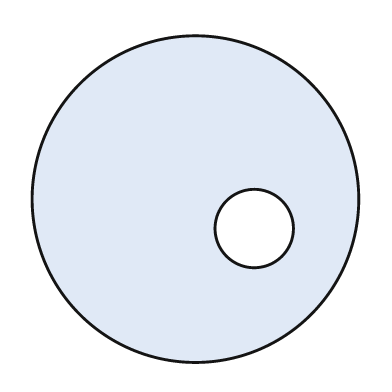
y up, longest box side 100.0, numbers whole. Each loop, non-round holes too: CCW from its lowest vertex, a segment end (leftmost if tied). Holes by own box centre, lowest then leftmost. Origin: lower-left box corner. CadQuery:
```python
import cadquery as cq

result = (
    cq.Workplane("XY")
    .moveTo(50.0, 50.0)
    .circle(50.0)
    .moveTo(68.0, 41.0)
    .circle(12.0)
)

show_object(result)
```